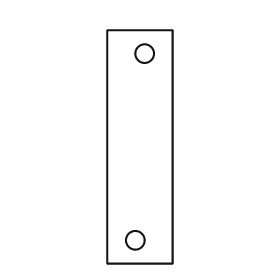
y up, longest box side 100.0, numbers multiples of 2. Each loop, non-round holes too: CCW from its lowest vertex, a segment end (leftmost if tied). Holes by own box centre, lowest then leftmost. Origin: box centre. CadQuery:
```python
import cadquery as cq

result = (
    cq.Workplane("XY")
    .moveTo(-14.0, -50.0)
    .lineTo(14.0, -50.0)
    .lineTo(14.0, 50.0)
    .lineTo(-14.0, 50.0)
    .close()
    .moveTo(-2.0, -40.0)
    .circle(4.0)
    .moveTo(2.0, 40.0)
    .circle(4.0)
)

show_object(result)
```